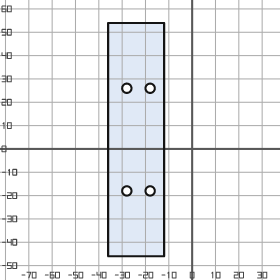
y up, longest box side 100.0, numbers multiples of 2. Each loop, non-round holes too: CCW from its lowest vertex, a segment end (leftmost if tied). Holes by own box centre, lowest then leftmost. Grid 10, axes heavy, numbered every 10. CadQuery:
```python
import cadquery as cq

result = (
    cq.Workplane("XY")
    .moveTo(-36.0, -46.0)
    .lineTo(-12.0, -46.0)
    .lineTo(-12.0, 54.0)
    .lineTo(-36.0, 54.0)
    .close()
    .moveTo(-28.0, -18.0)
    .circle(2.0)
    .moveTo(-18.0, -18.0)
    .circle(2.0)
    .moveTo(-28.0, 26.0)
    .circle(2.0)
    .moveTo(-18.0, 26.0)
    .circle(2.0)
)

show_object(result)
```